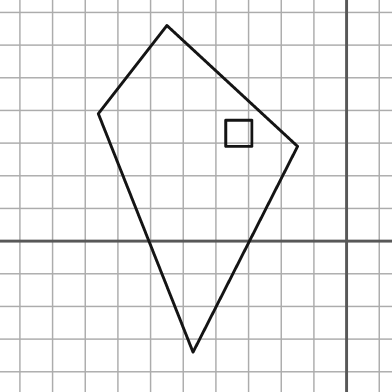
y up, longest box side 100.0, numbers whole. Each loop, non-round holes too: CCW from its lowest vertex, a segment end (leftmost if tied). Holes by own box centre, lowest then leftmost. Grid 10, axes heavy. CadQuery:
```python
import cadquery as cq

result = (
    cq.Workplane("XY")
    .moveTo(-47.0, -34.0)
    .lineTo(-15.0, 29.0)
    .lineTo(-55.0, 66.0)
    .lineTo(-76.0, 39.0)
    .close()
    .moveTo(-37.0, 29.0)
    .lineTo(-29.0, 29.0)
    .lineTo(-29.0, 37.0)
    .lineTo(-37.0, 37.0)
    .close()
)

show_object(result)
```